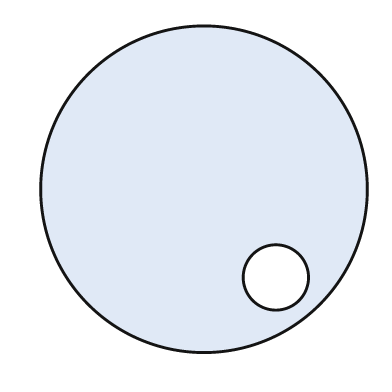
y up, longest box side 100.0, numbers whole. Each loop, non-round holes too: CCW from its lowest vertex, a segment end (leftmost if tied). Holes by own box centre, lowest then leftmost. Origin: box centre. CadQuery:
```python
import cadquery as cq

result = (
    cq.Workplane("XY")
    .moveTo(0.0, 0.0)
    .circle(50.0)
    .moveTo(22.0, -27.0)
    .circle(10.0)
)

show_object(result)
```